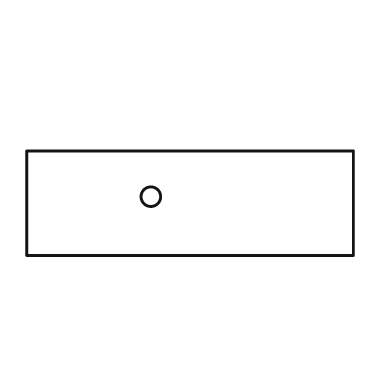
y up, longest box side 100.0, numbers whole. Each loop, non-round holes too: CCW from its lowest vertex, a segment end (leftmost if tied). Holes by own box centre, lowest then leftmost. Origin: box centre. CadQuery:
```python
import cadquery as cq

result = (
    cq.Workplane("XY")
    .moveTo(-50.0, -16.0)
    .lineTo(50.0, -16.0)
    .lineTo(50.0, 16.0)
    .lineTo(-50.0, 16.0)
    .close()
    .moveTo(-12.0, 2.0)
    .circle(3.0)
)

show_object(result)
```